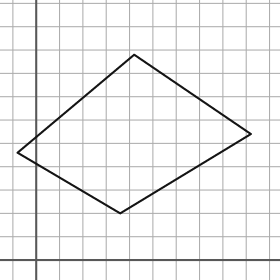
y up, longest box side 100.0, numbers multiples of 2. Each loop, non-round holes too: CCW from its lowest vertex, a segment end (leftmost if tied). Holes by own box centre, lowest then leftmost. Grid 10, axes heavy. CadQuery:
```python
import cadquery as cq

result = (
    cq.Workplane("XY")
    .moveTo(36.0, 20.0)
    .lineTo(92.0, 54.0)
    .lineTo(42.0, 88.0)
    .lineTo(-8.0, 46.0)
    .close()
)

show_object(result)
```